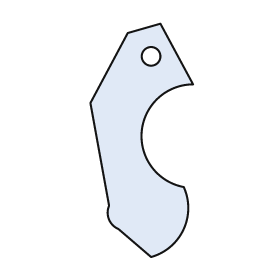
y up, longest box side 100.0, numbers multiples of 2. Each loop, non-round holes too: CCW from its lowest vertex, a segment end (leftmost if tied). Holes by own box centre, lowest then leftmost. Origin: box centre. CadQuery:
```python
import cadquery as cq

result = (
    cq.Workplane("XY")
    .moveTo(4.0, -50.0)
    .threePointArc((18.0, -38.0), (18.0, -20.0))
    .threePointArc((0.0, 4.0), (22.0, 24.0))
    .lineTo(8.0, 50.0)
    .lineTo(-6.0, 46.0)
    .lineTo(-22.0, 16.0)
    .lineTo(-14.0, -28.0)
    .threePointArc((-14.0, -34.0), (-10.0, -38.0))
    .close()
    .moveTo(4.0, 36.0)
    .circle(4.0)
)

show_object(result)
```